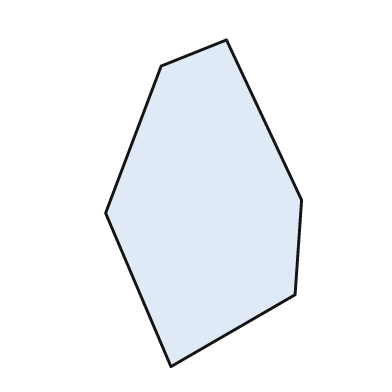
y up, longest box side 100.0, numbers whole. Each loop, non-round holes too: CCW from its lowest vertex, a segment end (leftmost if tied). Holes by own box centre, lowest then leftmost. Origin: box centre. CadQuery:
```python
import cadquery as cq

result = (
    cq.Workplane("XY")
    .moveTo(-10.0, -50.0)
    .lineTo(28.0, -28.0)
    .lineTo(30.0, 1.0)
    .lineTo(7.0, 50.0)
    .lineTo(-13.0, 42.0)
    .lineTo(-30.0, -3.0)
    .close()
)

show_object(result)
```